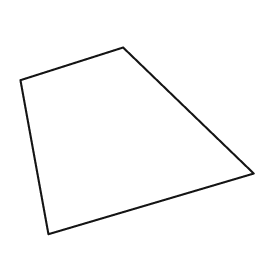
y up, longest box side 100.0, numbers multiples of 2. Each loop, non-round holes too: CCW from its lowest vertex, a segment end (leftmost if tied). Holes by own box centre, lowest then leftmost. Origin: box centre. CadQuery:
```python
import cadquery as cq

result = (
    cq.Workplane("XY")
    .moveTo(-38.0, -40.0)
    .lineTo(50.0, -14.0)
    .lineTo(-6.0, 40.0)
    .lineTo(-50.0, 26.0)
    .close()
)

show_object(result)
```